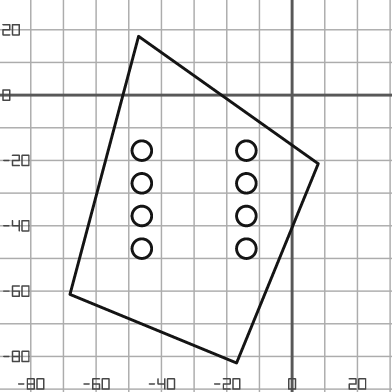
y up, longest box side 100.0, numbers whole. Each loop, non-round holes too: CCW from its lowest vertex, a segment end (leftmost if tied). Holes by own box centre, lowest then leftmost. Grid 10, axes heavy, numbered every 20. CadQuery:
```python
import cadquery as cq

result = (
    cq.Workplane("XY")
    .moveTo(-17.0, -82.0)
    .lineTo(8.0, -21.0)
    .lineTo(-47.0, 18.0)
    .lineTo(-68.0, -61.0)
    .close()
    .moveTo(-46.0, -47.0)
    .circle(3.0)
    .moveTo(-14.0, -47.0)
    .circle(3.0)
    .moveTo(-46.0, -37.0)
    .circle(3.0)
    .moveTo(-14.0, -37.0)
    .circle(3.0)
    .moveTo(-46.0, -27.0)
    .circle(3.0)
    .moveTo(-14.0, -27.0)
    .circle(3.0)
    .moveTo(-46.0, -17.0)
    .circle(3.0)
    .moveTo(-14.0, -17.0)
    .circle(3.0)
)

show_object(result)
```